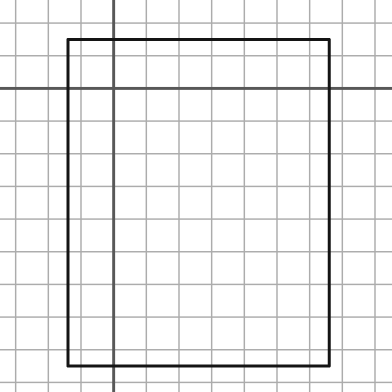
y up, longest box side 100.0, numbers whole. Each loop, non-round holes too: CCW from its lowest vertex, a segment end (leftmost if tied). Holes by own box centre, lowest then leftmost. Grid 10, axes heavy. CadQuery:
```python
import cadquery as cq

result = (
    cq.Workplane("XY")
    .moveTo(-14.0, -85.0)
    .lineTo(66.0, -85.0)
    .lineTo(66.0, 15.0)
    .lineTo(-14.0, 15.0)
    .close()
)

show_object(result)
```